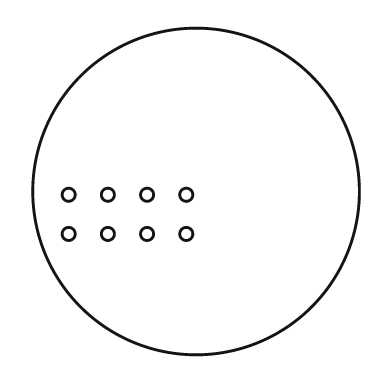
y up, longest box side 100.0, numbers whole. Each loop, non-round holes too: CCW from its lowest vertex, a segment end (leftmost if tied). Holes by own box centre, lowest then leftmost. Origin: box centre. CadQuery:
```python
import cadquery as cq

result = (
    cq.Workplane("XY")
    .moveTo(0.0, 0.0)
    .circle(50.0)
    .moveTo(-39.0, -13.0)
    .circle(2.0)
    .moveTo(-27.0, -13.0)
    .circle(2.0)
    .moveTo(-15.0, -13.0)
    .circle(2.0)
    .moveTo(-3.0, -13.0)
    .circle(2.0)
    .moveTo(-39.0, -1.0)
    .circle(2.0)
    .moveTo(-27.0, -1.0)
    .circle(2.0)
    .moveTo(-15.0, -1.0)
    .circle(2.0)
    .moveTo(-3.0, -1.0)
    .circle(2.0)
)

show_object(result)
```